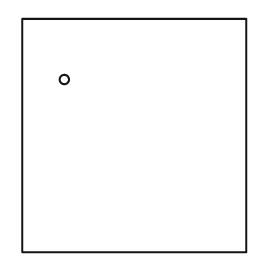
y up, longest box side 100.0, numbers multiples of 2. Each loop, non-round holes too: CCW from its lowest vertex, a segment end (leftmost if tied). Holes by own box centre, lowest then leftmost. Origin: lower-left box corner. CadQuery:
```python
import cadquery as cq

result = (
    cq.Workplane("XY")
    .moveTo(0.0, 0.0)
    .lineTo(96.0, 0.0)
    .lineTo(96.0, 100.0)
    .lineTo(0.0, 100.0)
    .close()
    .moveTo(18.0, 74.0)
    .circle(2.0)
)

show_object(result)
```